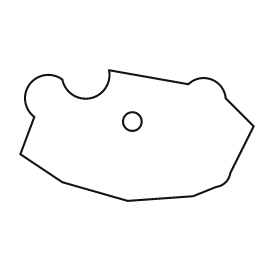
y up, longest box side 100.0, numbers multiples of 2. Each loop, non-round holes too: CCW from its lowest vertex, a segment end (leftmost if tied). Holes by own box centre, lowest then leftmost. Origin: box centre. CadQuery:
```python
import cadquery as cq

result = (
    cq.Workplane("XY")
    .moveTo(-4.0, -28.0)
    .lineTo(24.0, -26.0)
    .lineTo(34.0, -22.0)
    .threePointArc((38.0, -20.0), (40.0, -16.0))
    .lineTo(50.0, 4.0)
    .lineTo(38.0, 16.0)
    .threePointArc((32.0, 24.0), (22.0, 22.0))
    .lineTo(-12.0, 28.0)
    .threePointArc((-20.0, 16.0), (-32.0, 24.0))
    .threePointArc((-46.0, 22.0), (-44.0, 8.0))
    .lineTo(-50.0, -8.0)
    .lineTo(-32.0, -20.0)
    .close()
    .moveTo(-2.0, 6.0)
    .circle(4.0)
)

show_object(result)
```